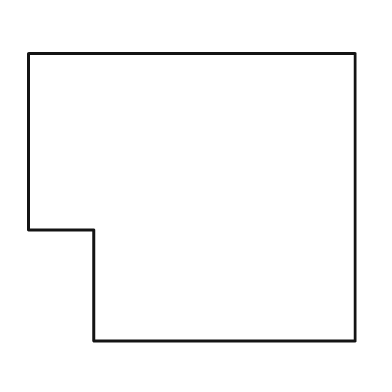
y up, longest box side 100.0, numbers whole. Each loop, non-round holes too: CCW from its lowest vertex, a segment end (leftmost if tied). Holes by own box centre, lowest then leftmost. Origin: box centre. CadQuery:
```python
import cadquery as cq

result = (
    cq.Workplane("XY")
    .moveTo(-30.0, -44.0)
    .lineTo(50.0, -44.0)
    .lineTo(50.0, 44.0)
    .lineTo(-50.0, 44.0)
    .lineTo(-50.0, -10.0)
    .lineTo(-30.0, -10.0)
    .close()
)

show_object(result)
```